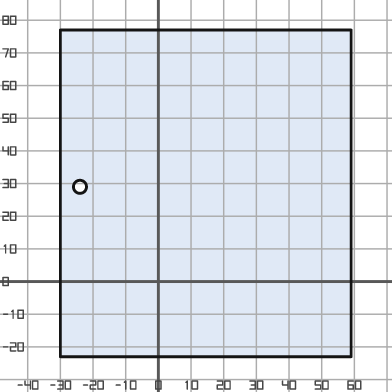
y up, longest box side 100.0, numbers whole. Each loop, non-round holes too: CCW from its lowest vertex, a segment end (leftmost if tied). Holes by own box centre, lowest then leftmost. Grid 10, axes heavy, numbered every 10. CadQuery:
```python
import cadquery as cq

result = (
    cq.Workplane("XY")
    .moveTo(-30.0, -23.0)
    .lineTo(59.0, -23.0)
    .lineTo(59.0, 77.0)
    .lineTo(-30.0, 77.0)
    .close()
    .moveTo(-24.0, 29.0)
    .circle(2.0)
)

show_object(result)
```